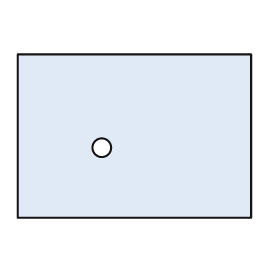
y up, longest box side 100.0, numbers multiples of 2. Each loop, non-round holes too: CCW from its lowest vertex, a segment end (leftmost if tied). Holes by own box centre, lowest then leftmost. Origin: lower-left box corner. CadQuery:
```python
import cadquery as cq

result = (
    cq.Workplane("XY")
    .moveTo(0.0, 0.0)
    .lineTo(100.0, 0.0)
    .lineTo(100.0, 70.0)
    .lineTo(0.0, 70.0)
    .close()
    .moveTo(36.0, 30.0)
    .circle(4.0)
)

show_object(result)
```